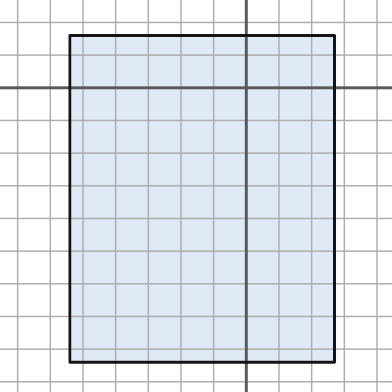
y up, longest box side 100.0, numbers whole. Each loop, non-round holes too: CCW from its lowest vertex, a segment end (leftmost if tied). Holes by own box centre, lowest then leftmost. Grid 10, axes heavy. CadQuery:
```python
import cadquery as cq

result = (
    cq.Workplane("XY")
    .moveTo(-54.0, -84.0)
    .lineTo(27.0, -84.0)
    .lineTo(27.0, 16.0)
    .lineTo(-54.0, 16.0)
    .close()
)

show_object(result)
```